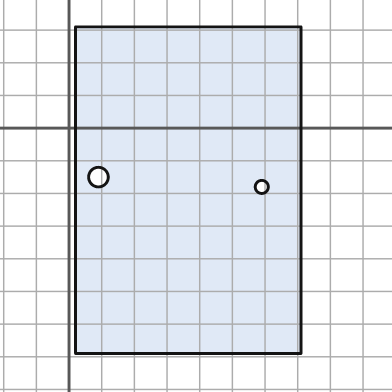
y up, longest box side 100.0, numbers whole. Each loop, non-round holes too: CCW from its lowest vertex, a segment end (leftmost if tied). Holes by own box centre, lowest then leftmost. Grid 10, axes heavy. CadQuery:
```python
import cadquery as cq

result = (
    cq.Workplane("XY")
    .moveTo(2.0, -69.0)
    .lineTo(71.0, -69.0)
    .lineTo(71.0, 31.0)
    .lineTo(2.0, 31.0)
    .close()
    .moveTo(59.0, -18.0)
    .circle(2.0)
    .moveTo(9.0, -15.0)
    .circle(3.0)
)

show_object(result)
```